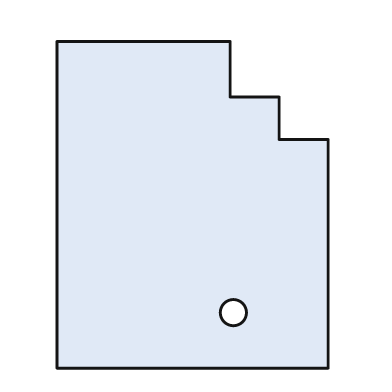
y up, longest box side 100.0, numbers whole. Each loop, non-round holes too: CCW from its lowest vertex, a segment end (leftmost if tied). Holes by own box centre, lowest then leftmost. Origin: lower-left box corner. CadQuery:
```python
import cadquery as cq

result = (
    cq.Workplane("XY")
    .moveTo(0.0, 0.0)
    .lineTo(83.0, 0.0)
    .lineTo(83.0, 70.0)
    .lineTo(68.0, 70.0)
    .lineTo(68.0, 83.0)
    .lineTo(53.0, 83.0)
    .lineTo(53.0, 100.0)
    .lineTo(0.0, 100.0)
    .close()
    .moveTo(54.0, 17.0)
    .circle(4.0)
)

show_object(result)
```